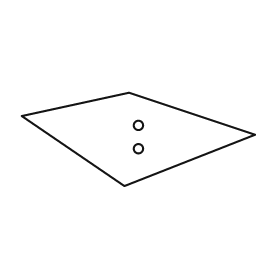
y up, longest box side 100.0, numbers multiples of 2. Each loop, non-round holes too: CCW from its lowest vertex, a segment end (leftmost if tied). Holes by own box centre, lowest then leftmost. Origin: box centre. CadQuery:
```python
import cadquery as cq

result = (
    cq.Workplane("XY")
    .moveTo(-6.0, -20.0)
    .lineTo(50.0, 2.0)
    .lineTo(-4.0, 20.0)
    .lineTo(-50.0, 10.0)
    .close()
    .moveTo(0.0, -4.0)
    .circle(2.0)
    .moveTo(0.0, 6.0)
    .circle(2.0)
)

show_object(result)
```